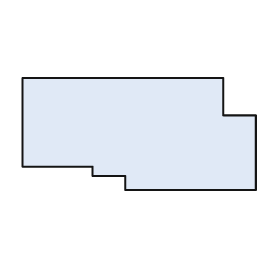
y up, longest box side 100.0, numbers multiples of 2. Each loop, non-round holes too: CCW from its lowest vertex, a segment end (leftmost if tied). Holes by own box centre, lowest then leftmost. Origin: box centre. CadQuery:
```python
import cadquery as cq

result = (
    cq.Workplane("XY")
    .moveTo(-6.0, -24.0)
    .lineTo(50.0, -24.0)
    .lineTo(50.0, 8.0)
    .lineTo(36.0, 8.0)
    .lineTo(36.0, 24.0)
    .lineTo(-50.0, 24.0)
    .lineTo(-50.0, -14.0)
    .lineTo(-20.0, -14.0)
    .lineTo(-20.0, -18.0)
    .lineTo(-6.0, -18.0)
    .close()
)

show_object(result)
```